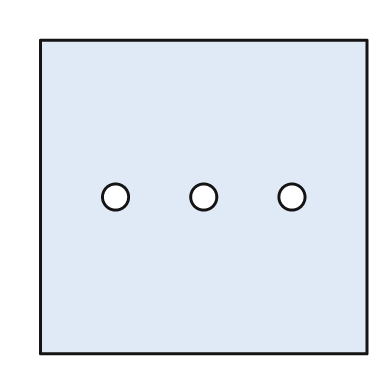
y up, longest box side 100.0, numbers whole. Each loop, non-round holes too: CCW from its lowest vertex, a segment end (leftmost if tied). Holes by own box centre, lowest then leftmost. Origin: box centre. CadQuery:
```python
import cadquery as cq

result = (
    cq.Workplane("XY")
    .moveTo(-50.0, -48.0)
    .lineTo(50.0, -48.0)
    .lineTo(50.0, 48.0)
    .lineTo(-50.0, 48.0)
    .close()
    .moveTo(-27.0, 0.0)
    .circle(4.0)
    .moveTo(0.0, 0.0)
    .circle(4.0)
    .moveTo(27.0, 0.0)
    .circle(4.0)
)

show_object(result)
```